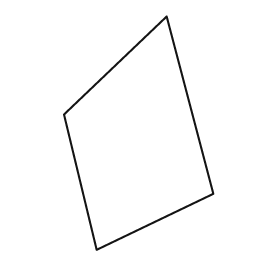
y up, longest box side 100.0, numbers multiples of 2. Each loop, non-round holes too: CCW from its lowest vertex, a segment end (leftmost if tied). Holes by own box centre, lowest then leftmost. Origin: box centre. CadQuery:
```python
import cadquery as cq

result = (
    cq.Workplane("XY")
    .moveTo(-18.0, -50.0)
    .lineTo(32.0, -26.0)
    .lineTo(12.0, 50.0)
    .lineTo(-32.0, 8.0)
    .close()
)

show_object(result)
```